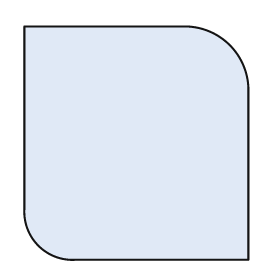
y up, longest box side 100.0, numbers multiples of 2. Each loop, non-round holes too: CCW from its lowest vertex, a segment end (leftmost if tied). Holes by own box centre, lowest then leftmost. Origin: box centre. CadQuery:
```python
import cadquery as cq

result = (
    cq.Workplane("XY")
    .moveTo(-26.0, -50.0)
    .lineTo(48.0, -50.0)
    .lineTo(48.0, 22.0)
    .threePointArc((40.0, 42.0), (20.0, 50.0))
    .lineTo(-48.0, 50.0)
    .lineTo(-48.0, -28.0)
    .threePointArc((-42.0, -44.0), (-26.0, -50.0))
    .close()
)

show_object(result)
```